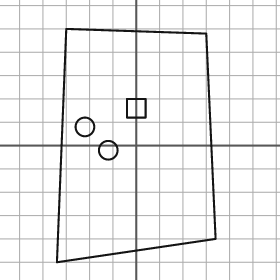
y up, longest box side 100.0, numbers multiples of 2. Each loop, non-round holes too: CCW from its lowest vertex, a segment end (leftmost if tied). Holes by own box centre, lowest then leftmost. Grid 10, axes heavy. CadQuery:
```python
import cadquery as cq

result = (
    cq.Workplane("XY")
    .moveTo(-34.0, -50.0)
    .lineTo(34.0, -40.0)
    .lineTo(30.0, 48.0)
    .lineTo(-30.0, 50.0)
    .close()
    .moveTo(-12.0, -2.0)
    .circle(4.0)
    .moveTo(-22.0, 8.0)
    .circle(4.0)
    .moveTo(-4.0, 12.0)
    .lineTo(4.0, 12.0)
    .lineTo(4.0, 20.0)
    .lineTo(-4.0, 20.0)
    .close()
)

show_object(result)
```